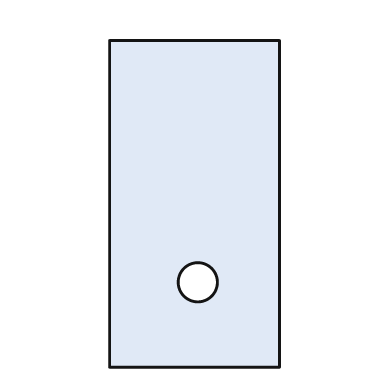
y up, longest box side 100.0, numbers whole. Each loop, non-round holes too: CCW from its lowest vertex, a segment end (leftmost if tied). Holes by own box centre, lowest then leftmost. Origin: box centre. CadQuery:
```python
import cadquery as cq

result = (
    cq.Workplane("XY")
    .moveTo(-26.0, -50.0)
    .lineTo(26.0, -50.0)
    .lineTo(26.0, 50.0)
    .lineTo(-26.0, 50.0)
    .close()
    .moveTo(1.0, -24.0)
    .circle(6.0)
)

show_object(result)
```